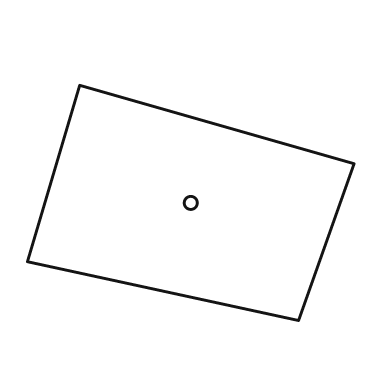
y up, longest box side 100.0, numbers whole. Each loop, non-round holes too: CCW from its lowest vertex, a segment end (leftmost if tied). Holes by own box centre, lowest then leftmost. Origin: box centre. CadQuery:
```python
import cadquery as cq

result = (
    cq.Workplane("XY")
    .moveTo(33.0, -36.0)
    .lineTo(50.0, 12.0)
    .lineTo(-34.0, 36.0)
    .lineTo(-50.0, -18.0)
    .close()
    .moveTo(0.0, 0.0)
    .circle(2.0)
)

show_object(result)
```